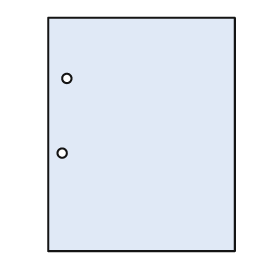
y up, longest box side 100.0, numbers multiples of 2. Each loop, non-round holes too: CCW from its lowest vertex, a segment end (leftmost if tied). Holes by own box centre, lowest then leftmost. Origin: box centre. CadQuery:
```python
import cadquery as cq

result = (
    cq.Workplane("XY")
    .moveTo(-40.0, -50.0)
    .lineTo(40.0, -50.0)
    .lineTo(40.0, 50.0)
    .lineTo(-40.0, 50.0)
    .close()
    .moveTo(-34.0, -8.0)
    .circle(2.0)
    .moveTo(-32.0, 24.0)
    .circle(2.0)
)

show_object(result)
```